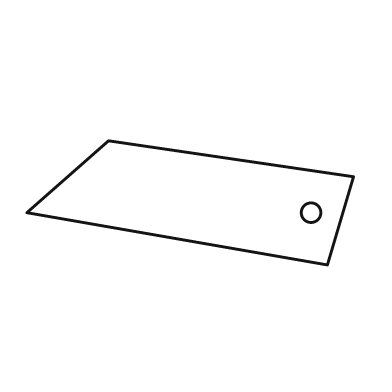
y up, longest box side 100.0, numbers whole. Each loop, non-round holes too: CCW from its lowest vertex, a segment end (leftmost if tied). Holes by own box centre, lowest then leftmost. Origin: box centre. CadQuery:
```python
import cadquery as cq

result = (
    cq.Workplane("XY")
    .moveTo(42.0, -19.0)
    .lineTo(50.0, 8.0)
    .lineTo(-25.0, 19.0)
    .lineTo(-50.0, -3.0)
    .close()
    .moveTo(37.0, -3.0)
    .circle(3.0)
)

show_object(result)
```